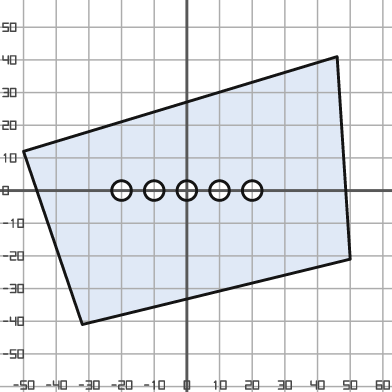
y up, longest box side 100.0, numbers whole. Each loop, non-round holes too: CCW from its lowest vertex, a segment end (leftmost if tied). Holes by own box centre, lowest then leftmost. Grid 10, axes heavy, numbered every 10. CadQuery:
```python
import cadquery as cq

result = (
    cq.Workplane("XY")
    .moveTo(-32.0, -41.0)
    .lineTo(50.0, -21.0)
    .lineTo(46.0, 41.0)
    .lineTo(-50.0, 12.0)
    .close()
    .moveTo(-20.0, 0.0)
    .circle(3.0)
    .moveTo(-10.0, 0.0)
    .circle(3.0)
    .moveTo(0.0, 0.0)
    .circle(3.0)
    .moveTo(10.0, 0.0)
    .circle(3.0)
    .moveTo(20.0, 0.0)
    .circle(3.0)
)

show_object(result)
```